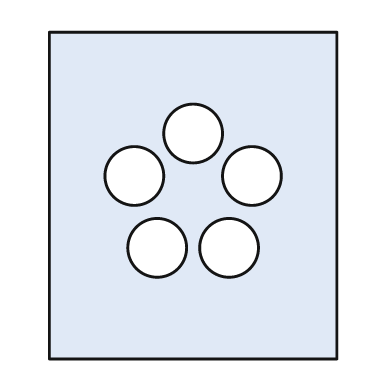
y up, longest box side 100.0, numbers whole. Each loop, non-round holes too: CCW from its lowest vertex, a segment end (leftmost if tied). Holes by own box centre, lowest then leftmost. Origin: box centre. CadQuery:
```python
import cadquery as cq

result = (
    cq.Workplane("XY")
    .moveTo(-44.0, -50.0)
    .lineTo(44.0, -50.0)
    .lineTo(44.0, 50.0)
    .lineTo(-44.0, 50.0)
    .close()
    .moveTo(-11.0, -16.0)
    .circle(9.0)
    .moveTo(11.0, -16.0)
    .circle(9.0)
    .moveTo(-18.0, 6.0)
    .circle(9.0)
    .moveTo(18.0, 6.0)
    .circle(9.0)
    .moveTo(0.0, 19.0)
    .circle(9.0)
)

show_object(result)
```